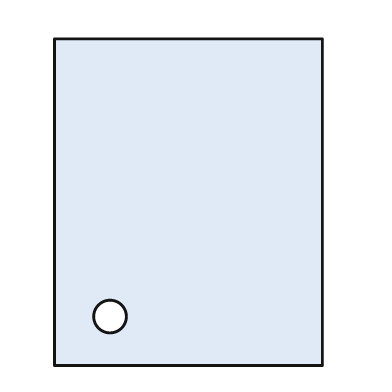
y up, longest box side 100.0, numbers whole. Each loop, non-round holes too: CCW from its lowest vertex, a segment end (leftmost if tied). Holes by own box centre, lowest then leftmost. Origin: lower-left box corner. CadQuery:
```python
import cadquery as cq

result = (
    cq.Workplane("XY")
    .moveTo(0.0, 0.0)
    .lineTo(82.0, 0.0)
    .lineTo(82.0, 100.0)
    .lineTo(0.0, 100.0)
    .close()
    .moveTo(17.0, 15.0)
    .circle(5.0)
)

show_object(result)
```